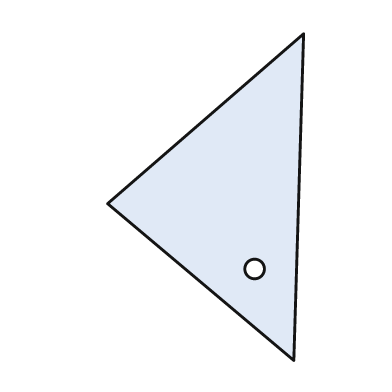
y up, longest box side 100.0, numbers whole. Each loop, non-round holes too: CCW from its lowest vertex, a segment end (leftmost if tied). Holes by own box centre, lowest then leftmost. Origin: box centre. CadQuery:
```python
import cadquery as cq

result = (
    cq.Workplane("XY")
    .moveTo(27.0, -50.0)
    .lineTo(30.0, 50.0)
    .lineTo(-30.0, -2.0)
    .close()
    .moveTo(15.0, -22.0)
    .circle(3.0)
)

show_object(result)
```